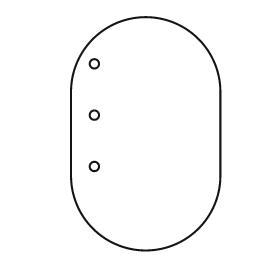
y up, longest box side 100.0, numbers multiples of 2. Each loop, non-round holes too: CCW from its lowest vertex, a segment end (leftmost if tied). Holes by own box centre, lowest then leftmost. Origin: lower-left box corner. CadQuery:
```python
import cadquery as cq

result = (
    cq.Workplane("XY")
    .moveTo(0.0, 32.0)
    .threePointArc((32.0, 0.0), (64.0, 32.0))
    .lineTo(64.0, 68.0)
    .threePointArc((32.0, 100.0), (0.0, 68.0))
    .close()
    .moveTo(10.0, 36.0)
    .circle(2.0)
    .moveTo(10.0, 58.0)
    .circle(2.0)
    .moveTo(10.0, 80.0)
    .circle(2.0)
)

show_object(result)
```